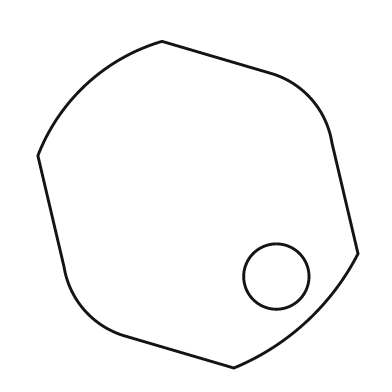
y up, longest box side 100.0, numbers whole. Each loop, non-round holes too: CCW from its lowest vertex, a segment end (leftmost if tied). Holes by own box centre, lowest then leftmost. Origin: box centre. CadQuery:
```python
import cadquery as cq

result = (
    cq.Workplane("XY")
    .moveTo(11.0, -50.0)
    .threePointArc((33.0, -36.0), (49.0, -15.0))
    .lineTo(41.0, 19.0)
    .threePointArc((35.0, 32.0), (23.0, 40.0))
    .lineTo(-11.0, 50.0)
    .threePointArc((-34.0, 37.0), (-49.0, 15.0))
    .lineTo(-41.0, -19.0)
    .threePointArc((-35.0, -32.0), (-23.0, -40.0))
    .close()
    .moveTo(24.0, -22.0)
    .circle(10.0)
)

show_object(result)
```